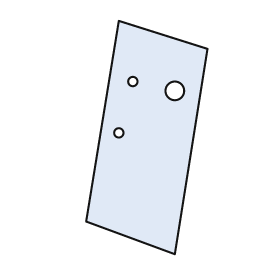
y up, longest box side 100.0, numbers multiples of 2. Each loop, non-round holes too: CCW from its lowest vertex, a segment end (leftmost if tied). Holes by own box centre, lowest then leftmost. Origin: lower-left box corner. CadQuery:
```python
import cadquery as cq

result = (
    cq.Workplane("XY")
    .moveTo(38.0, 0.0)
    .lineTo(52.0, 88.0)
    .lineTo(14.0, 100.0)
    .lineTo(0.0, 14.0)
    .close()
    .moveTo(14.0, 52.0)
    .circle(2.0)
    .moveTo(38.0, 70.0)
    .circle(4.0)
    .moveTo(20.0, 74.0)
    .circle(2.0)
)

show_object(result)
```